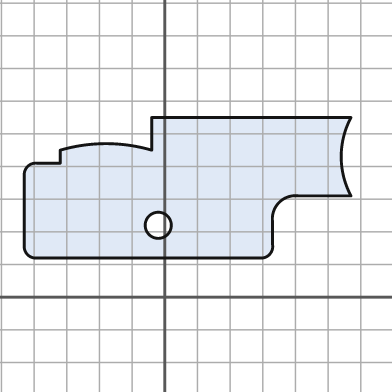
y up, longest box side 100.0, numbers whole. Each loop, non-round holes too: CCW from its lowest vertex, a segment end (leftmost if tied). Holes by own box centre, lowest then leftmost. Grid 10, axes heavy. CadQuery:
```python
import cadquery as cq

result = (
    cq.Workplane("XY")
    .moveTo(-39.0, 12.0)
    .lineTo(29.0, 12.0)
    .threePointArc((32.0, 13.0), (33.0, 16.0))
    .lineTo(33.0, 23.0)
    .threePointArc((35.0, 29.0), (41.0, 31.0))
    .lineTo(57.0, 31.0)
    .threePointArc((54.0, 43.0), (57.0, 55.0))
    .lineTo(-4.0, 55.0)
    .lineTo(-4.0, 45.0)
    .threePointArc((-18.0, 47.0), (-32.0, 45.0))
    .lineTo(-32.0, 41.0)
    .lineTo(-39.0, 41.0)
    .threePointArc((-42.0, 40.0), (-43.0, 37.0))
    .lineTo(-43.0, 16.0)
    .threePointArc((-42.0, 13.0), (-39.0, 12.0))
    .close()
    .moveTo(-2.0, 22.0)
    .circle(4.0)
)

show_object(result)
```